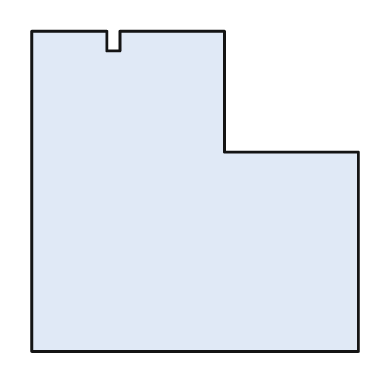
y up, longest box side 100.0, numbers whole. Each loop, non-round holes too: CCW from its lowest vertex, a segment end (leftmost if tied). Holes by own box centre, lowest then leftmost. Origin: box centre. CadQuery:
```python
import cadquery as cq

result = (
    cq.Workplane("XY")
    .moveTo(-50.0, -49.0)
    .lineTo(50.0, -49.0)
    .lineTo(50.0, 12.0)
    .lineTo(9.0, 12.0)
    .lineTo(9.0, 49.0)
    .lineTo(-23.0, 49.0)
    .lineTo(-23.0, 43.0)
    .lineTo(-27.0, 43.0)
    .lineTo(-27.0, 49.0)
    .lineTo(-50.0, 49.0)
    .close()
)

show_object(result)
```